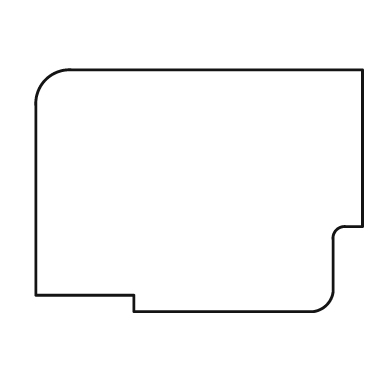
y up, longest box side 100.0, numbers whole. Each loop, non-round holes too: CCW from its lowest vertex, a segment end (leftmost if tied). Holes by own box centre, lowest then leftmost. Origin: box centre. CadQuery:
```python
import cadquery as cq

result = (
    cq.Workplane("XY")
    .moveTo(-20.0, -37.0)
    .lineTo(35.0, -37.0)
    .threePointArc((39.0, -35.0), (41.0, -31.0))
    .lineTo(41.0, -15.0)
    .threePointArc((42.0, -12.0), (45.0, -11.0))
    .lineTo(50.0, -11.0)
    .lineTo(50.0, 37.0)
    .lineTo(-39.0, 37.0)
    .threePointArc((-47.0, 34.0), (-50.0, 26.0))
    .lineTo(-50.0, -32.0)
    .lineTo(-20.0, -32.0)
    .close()
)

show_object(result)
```